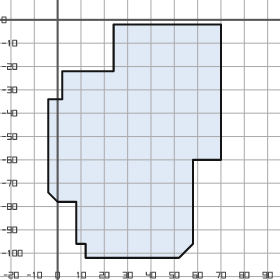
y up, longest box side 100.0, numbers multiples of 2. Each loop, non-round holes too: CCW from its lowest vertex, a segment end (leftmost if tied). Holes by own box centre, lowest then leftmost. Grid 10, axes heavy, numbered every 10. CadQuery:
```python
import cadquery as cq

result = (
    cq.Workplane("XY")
    .moveTo(12.0, -102.0)
    .lineTo(52.0, -102.0)
    .lineTo(58.0, -96.0)
    .lineTo(58.0, -60.0)
    .lineTo(70.0, -60.0)
    .lineTo(70.0, -2.0)
    .lineTo(24.0, -2.0)
    .lineTo(24.0, -22.0)
    .lineTo(2.0, -22.0)
    .lineTo(2.0, -34.0)
    .lineTo(-4.0, -34.0)
    .lineTo(-4.0, -74.0)
    .lineTo(0.0, -78.0)
    .lineTo(8.0, -78.0)
    .lineTo(8.0, -96.0)
    .lineTo(12.0, -96.0)
    .close()
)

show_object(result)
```